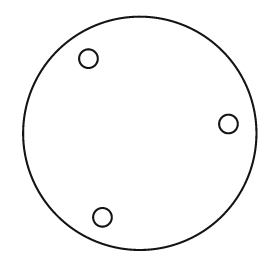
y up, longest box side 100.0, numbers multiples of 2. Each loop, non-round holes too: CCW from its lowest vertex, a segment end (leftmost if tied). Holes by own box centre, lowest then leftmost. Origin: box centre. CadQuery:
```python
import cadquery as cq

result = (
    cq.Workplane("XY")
    .moveTo(0.0, 0.0)
    .circle(50.0)
    .moveTo(-16.0, -36.0)
    .circle(4.0)
    .moveTo(38.0, 4.0)
    .circle(4.0)
    .moveTo(-22.0, 32.0)
    .circle(4.0)
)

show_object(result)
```